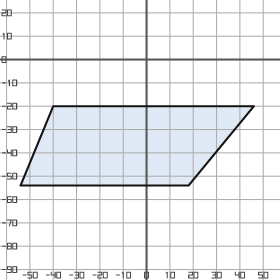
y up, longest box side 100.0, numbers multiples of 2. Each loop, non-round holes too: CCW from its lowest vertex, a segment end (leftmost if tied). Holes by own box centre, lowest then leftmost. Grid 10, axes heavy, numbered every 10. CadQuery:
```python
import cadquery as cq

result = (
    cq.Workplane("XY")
    .moveTo(-54.0, -54.0)
    .lineTo(18.0, -54.0)
    .lineTo(46.0, -20.0)
    .lineTo(-40.0, -20.0)
    .close()
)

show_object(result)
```